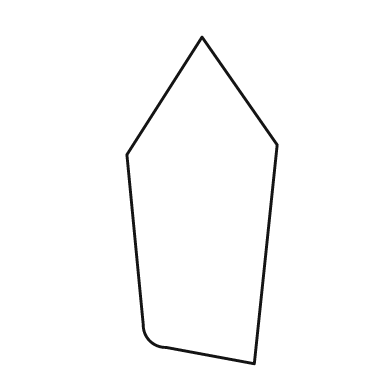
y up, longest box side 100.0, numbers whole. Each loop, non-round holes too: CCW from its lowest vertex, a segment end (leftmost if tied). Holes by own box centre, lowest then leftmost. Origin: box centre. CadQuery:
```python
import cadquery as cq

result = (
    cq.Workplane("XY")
    .moveTo(16.0, -50.0)
    .lineTo(23.0, 17.0)
    .lineTo(0.0, 50.0)
    .lineTo(-23.0, 14.0)
    .lineTo(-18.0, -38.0)
    .threePointArc((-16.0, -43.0), (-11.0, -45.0))
    .close()
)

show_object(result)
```